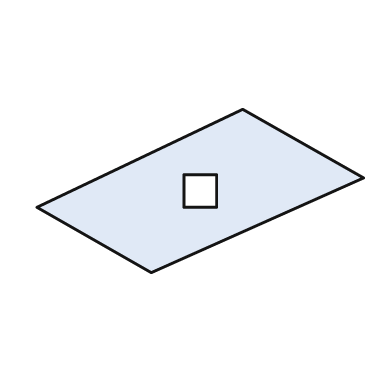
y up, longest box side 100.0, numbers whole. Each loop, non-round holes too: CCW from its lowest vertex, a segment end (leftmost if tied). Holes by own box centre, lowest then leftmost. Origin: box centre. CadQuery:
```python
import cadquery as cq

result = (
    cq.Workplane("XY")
    .moveTo(-15.0, -25.0)
    .lineTo(50.0, 4.0)
    .lineTo(13.0, 25.0)
    .lineTo(-50.0, -5.0)
    .close()
    .moveTo(-5.0, -5.0)
    .lineTo(5.0, -5.0)
    .lineTo(5.0, 5.0)
    .lineTo(-5.0, 5.0)
    .close()
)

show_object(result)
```